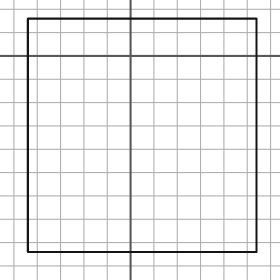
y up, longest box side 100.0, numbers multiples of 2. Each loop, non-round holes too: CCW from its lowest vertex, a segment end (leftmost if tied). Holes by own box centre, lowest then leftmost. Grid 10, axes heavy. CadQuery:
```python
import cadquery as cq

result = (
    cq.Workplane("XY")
    .moveTo(-44.0, -84.0)
    .lineTo(54.0, -84.0)
    .lineTo(54.0, 16.0)
    .lineTo(-44.0, 16.0)
    .close()
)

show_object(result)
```